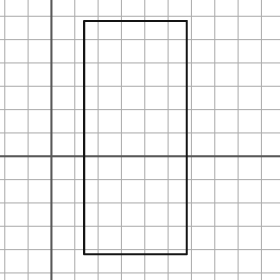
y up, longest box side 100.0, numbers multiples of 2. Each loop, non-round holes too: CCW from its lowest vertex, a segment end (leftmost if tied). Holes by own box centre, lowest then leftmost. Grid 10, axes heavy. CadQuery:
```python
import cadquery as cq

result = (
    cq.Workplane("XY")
    .moveTo(14.0, -42.0)
    .lineTo(58.0, -42.0)
    .lineTo(58.0, 58.0)
    .lineTo(14.0, 58.0)
    .close()
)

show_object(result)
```